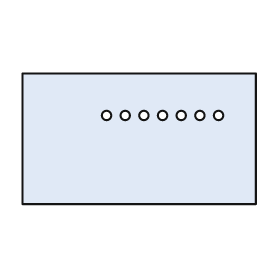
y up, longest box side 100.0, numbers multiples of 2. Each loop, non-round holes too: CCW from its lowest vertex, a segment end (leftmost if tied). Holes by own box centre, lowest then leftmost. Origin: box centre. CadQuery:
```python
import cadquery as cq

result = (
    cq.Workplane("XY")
    .moveTo(-50.0, -28.0)
    .lineTo(50.0, -28.0)
    .lineTo(50.0, 28.0)
    .lineTo(-50.0, 28.0)
    .close()
    .moveTo(-14.0, 10.0)
    .circle(2.0)
    .moveTo(-6.0, 10.0)
    .circle(2.0)
    .moveTo(2.0, 10.0)
    .circle(2.0)
    .moveTo(10.0, 10.0)
    .circle(2.0)
    .moveTo(18.0, 10.0)
    .circle(2.0)
    .moveTo(26.0, 10.0)
    .circle(2.0)
    .moveTo(34.0, 10.0)
    .circle(2.0)
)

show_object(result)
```